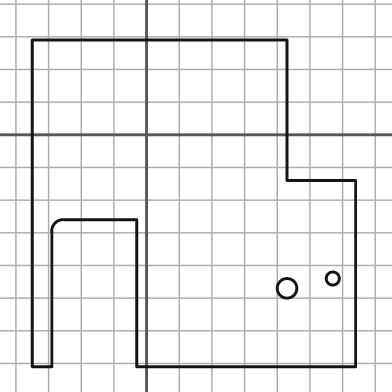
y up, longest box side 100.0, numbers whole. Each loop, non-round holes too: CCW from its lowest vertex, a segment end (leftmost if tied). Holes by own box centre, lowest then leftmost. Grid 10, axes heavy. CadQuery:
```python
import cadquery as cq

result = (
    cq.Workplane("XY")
    .moveTo(-35.0, -71.0)
    .lineTo(-29.0, -71.0)
    .lineTo(-29.0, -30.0)
    .threePointArc((-28.0, -27.0), (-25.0, -26.0))
    .lineTo(-3.0, -26.0)
    .lineTo(-3.0, -71.0)
    .lineTo(64.0, -71.0)
    .lineTo(64.0, -14.0)
    .lineTo(43.0, -14.0)
    .lineTo(43.0, 29.0)
    .lineTo(-35.0, 29.0)
    .close()
    .moveTo(43.0, -47.0)
    .circle(3.0)
    .moveTo(57.0, -44.0)
    .circle(2.0)
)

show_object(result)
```